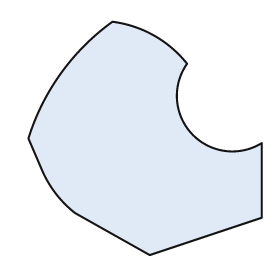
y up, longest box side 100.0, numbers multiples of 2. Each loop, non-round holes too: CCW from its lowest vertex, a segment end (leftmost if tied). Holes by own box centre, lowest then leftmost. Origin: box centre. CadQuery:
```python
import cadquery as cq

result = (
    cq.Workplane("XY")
    .moveTo(2.0, -50.0)
    .lineTo(50.0, -34.0)
    .lineTo(50.0, -2.0)
    .threePointArc((20.0, 2.0), (18.0, 32.0))
    .threePointArc((4.0, 44.0), (-14.0, 50.0))
    .threePointArc((-36.0, 28.0), (-50.0, 0.0))
    .lineTo(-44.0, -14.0)
    .threePointArc((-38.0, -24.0), (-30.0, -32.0))
    .close()
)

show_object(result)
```